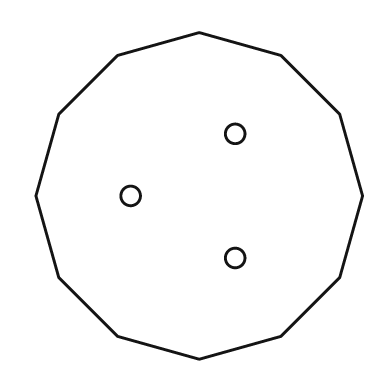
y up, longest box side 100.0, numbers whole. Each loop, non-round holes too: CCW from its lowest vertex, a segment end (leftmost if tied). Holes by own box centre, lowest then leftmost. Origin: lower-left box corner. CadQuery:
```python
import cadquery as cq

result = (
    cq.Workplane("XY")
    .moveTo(50.0, 0.0)
    .lineTo(75.0, 7.0)
    .lineTo(93.0, 25.0)
    .lineTo(100.0, 50.0)
    .lineTo(93.0, 75.0)
    .lineTo(75.0, 93.0)
    .lineTo(50.0, 100.0)
    .lineTo(25.0, 93.0)
    .lineTo(7.0, 75.0)
    .lineTo(0.0, 50.0)
    .lineTo(7.0, 25.0)
    .lineTo(25.0, 7.0)
    .close()
    .moveTo(61.0, 31.0)
    .circle(3.0)
    .moveTo(29.0, 50.0)
    .circle(3.0)
    .moveTo(61.0, 69.0)
    .circle(3.0)
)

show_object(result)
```